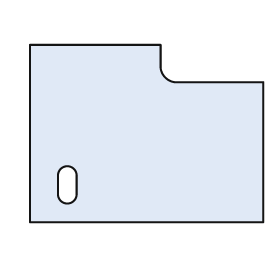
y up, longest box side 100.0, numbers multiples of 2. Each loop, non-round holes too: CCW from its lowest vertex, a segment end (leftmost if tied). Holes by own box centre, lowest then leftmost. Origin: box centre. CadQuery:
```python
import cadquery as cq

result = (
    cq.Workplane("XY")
    .moveTo(-50.0, -38.0)
    .lineTo(50.0, -38.0)
    .lineTo(50.0, 22.0)
    .lineTo(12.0, 22.0)
    .threePointArc((8.0, 24.0), (6.0, 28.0))
    .lineTo(6.0, 38.0)
    .lineTo(-50.0, 38.0)
    .close()
    .moveTo(-38.0, -26.0)
    .threePointArc((-34.0, -30.0), (-30.0, -26.0))
    .lineTo(-30.0, -18.0)
    .threePointArc((-34.0, -14.0), (-38.0, -18.0))
    .close()
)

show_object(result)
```